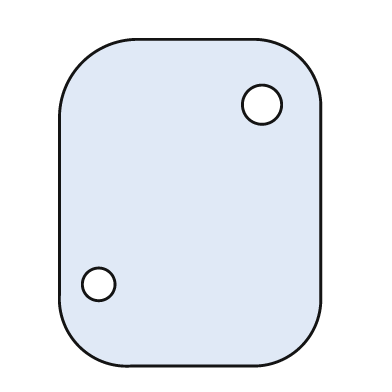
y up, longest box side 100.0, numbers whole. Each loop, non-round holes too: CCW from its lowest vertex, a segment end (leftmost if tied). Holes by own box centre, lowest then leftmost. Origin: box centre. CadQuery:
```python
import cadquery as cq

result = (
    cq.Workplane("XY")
    .moveTo(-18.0, -50.0)
    .lineTo(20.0, -50.0)
    .threePointArc((34.0, -44.0), (40.0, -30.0))
    .lineTo(40.0, 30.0)
    .threePointArc((34.0, 44.0), (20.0, 50.0))
    .lineTo(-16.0, 50.0)
    .threePointArc((-33.0, 43.0), (-40.0, 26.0))
    .lineTo(-40.0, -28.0)
    .threePointArc((-34.0, -44.0), (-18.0, -50.0))
    .close()
    .moveTo(-28.0, -25.0)
    .circle(5.0)
    .moveTo(22.0, 30.0)
    .circle(6.0)
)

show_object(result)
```